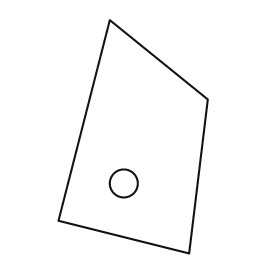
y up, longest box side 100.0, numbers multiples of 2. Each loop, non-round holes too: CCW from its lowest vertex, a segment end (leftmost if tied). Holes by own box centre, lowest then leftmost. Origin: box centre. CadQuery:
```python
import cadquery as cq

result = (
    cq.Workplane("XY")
    .moveTo(24.0, -50.0)
    .lineTo(32.0, 16.0)
    .lineTo(-10.0, 50.0)
    .lineTo(-32.0, -36.0)
    .close()
    .moveTo(-4.0, -20.0)
    .circle(6.0)
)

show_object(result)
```